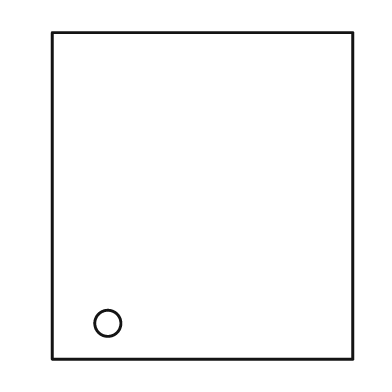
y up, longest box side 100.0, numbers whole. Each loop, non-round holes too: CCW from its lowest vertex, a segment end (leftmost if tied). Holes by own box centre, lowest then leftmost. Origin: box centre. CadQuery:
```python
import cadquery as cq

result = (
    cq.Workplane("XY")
    .moveTo(-46.0, -50.0)
    .lineTo(46.0, -50.0)
    .lineTo(46.0, 50.0)
    .lineTo(-46.0, 50.0)
    .close()
    .moveTo(-29.0, -39.0)
    .circle(4.0)
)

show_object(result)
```